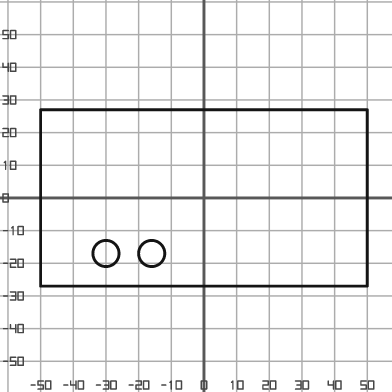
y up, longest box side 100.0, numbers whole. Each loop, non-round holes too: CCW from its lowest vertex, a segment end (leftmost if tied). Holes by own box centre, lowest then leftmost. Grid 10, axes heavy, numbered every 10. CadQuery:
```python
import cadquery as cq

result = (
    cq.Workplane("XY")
    .moveTo(-50.0, -27.0)
    .lineTo(50.0, -27.0)
    .lineTo(50.0, 27.0)
    .lineTo(-50.0, 27.0)
    .close()
    .moveTo(-30.0, -17.0)
    .circle(4.0)
    .moveTo(-16.0, -17.0)
    .circle(4.0)
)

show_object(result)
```